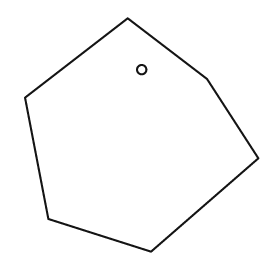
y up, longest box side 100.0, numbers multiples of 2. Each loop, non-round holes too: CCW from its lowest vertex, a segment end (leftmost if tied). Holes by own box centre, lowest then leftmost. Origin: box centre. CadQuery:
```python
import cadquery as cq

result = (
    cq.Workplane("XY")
    .moveTo(4.0, -50.0)
    .lineTo(50.0, -10.0)
    .lineTo(28.0, 24.0)
    .lineTo(-6.0, 50.0)
    .lineTo(-50.0, 16.0)
    .lineTo(-40.0, -36.0)
    .close()
    .moveTo(0.0, 28.0)
    .circle(2.0)
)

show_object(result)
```